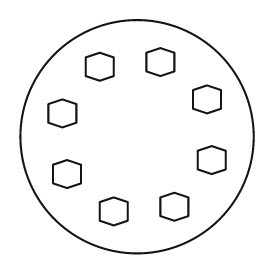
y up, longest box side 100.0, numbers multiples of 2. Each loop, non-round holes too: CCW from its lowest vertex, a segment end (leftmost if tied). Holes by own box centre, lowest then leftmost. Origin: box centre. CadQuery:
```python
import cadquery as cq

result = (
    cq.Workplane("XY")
    .moveTo(0.0, 0.0)
    .circle(50.0)
    .moveTo(-10.0, -38.0)
    .lineTo(-4.0, -36.0)
    .lineTo(-4.0, -28.0)
    .lineTo(-10.0, -26.0)
    .lineTo(-16.0, -28.0)
    .lineTo(-16.0, -36.0)
    .close()
    .moveTo(16.0, -36.0)
    .lineTo(22.0, -34.0)
    .lineTo(22.0, -26.0)
    .lineTo(16.0, -24.0)
    .lineTo(10.0, -26.0)
    .lineTo(10.0, -34.0)
    .close()
    .moveTo(-30.0, -22.0)
    .lineTo(-24.0, -20.0)
    .lineTo(-24.0, -12.0)
    .lineTo(-30.0, -10.0)
    .lineTo(-36.0, -12.0)
    .lineTo(-36.0, -20.0)
    .close()
    .moveTo(32.0, -16.0)
    .lineTo(38.0, -14.0)
    .lineTo(38.0, -6.0)
    .lineTo(32.0, -4.0)
    .lineTo(26.0, -6.0)
    .lineTo(26.0, -14.0)
    .close()
    .moveTo(-32.0, 4.0)
    .lineTo(-26.0, 6.0)
    .lineTo(-26.0, 14.0)
    .lineTo(-32.0, 16.0)
    .lineTo(-38.0, 14.0)
    .lineTo(-38.0, 6.0)
    .close()
    .moveTo(30.0, 10.0)
    .lineTo(36.0, 12.0)
    .lineTo(36.0, 20.0)
    .lineTo(30.0, 22.0)
    .lineTo(24.0, 20.0)
    .lineTo(24.0, 12.0)
    .close()
    .moveTo(-16.0, 24.0)
    .lineTo(-10.0, 26.0)
    .lineTo(-10.0, 34.0)
    .lineTo(-16.0, 36.0)
    .lineTo(-22.0, 34.0)
    .lineTo(-22.0, 26.0)
    .close()
    .moveTo(10.0, 26.0)
    .lineTo(16.0, 28.0)
    .lineTo(16.0, 36.0)
    .lineTo(10.0, 38.0)
    .lineTo(4.0, 36.0)
    .lineTo(4.0, 28.0)
    .close()
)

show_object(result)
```